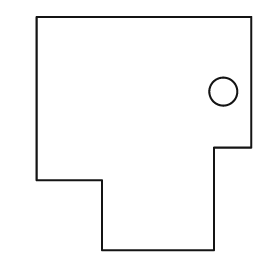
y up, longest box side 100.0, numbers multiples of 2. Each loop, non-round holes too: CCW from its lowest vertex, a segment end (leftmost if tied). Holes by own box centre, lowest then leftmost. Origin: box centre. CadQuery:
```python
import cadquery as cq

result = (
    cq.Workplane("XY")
    .moveTo(-18.0, -50.0)
    .lineTo(30.0, -50.0)
    .lineTo(30.0, -6.0)
    .lineTo(46.0, -6.0)
    .lineTo(46.0, 50.0)
    .lineTo(-46.0, 50.0)
    .lineTo(-46.0, -20.0)
    .lineTo(-18.0, -20.0)
    .close()
    .moveTo(34.0, 18.0)
    .circle(6.0)
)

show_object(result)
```